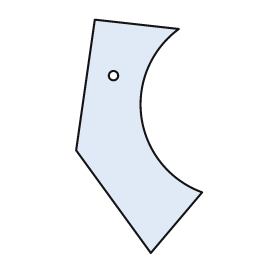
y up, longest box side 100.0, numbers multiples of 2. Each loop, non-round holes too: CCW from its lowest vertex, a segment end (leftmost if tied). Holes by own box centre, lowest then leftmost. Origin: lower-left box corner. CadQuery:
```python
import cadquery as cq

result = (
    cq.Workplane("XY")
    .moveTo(32.0, 0.0)
    .lineTo(54.0, 26.0)
    .threePointArc((28.0, 58.0), (44.0, 96.0))
    .lineTo(8.0, 100.0)
    .lineTo(0.0, 44.0)
    .close()
    .moveTo(16.0, 76.0)
    .circle(2.0)
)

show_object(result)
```